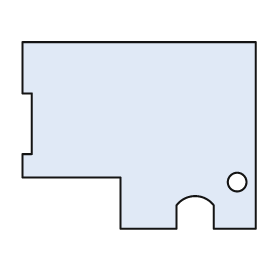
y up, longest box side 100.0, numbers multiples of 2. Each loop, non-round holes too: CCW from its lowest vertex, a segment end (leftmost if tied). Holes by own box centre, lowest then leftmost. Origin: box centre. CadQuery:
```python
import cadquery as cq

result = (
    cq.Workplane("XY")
    .moveTo(-8.0, -40.0)
    .lineTo(16.0, -40.0)
    .lineTo(16.0, -30.0)
    .threePointArc((24.0, -26.0), (32.0, -30.0))
    .lineTo(32.0, -40.0)
    .lineTo(50.0, -40.0)
    .lineTo(50.0, 40.0)
    .lineTo(-50.0, 40.0)
    .lineTo(-50.0, 18.0)
    .lineTo(-46.0, 18.0)
    .lineTo(-46.0, -8.0)
    .lineTo(-50.0, -8.0)
    .lineTo(-50.0, -18.0)
    .lineTo(-8.0, -18.0)
    .close()
    .moveTo(42.0, -20.0)
    .circle(4.0)
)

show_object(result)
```